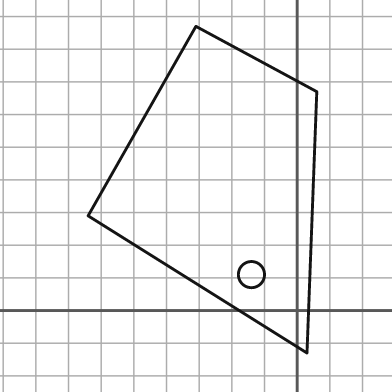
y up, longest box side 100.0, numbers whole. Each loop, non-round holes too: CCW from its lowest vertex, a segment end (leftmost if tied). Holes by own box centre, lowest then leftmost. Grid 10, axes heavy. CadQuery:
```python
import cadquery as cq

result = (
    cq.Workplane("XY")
    .moveTo(3.0, -13.0)
    .lineTo(6.0, 67.0)
    .lineTo(-31.0, 87.0)
    .lineTo(-64.0, 29.0)
    .close()
    .moveTo(-14.0, 11.0)
    .circle(4.0)
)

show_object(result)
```